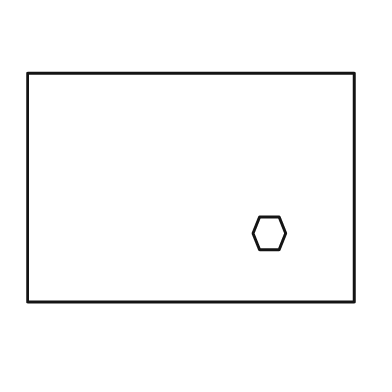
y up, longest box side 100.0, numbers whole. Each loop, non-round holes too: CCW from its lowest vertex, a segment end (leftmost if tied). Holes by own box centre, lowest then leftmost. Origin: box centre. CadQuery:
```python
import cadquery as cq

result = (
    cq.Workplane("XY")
    .moveTo(-50.0, -35.0)
    .lineTo(50.0, -35.0)
    .lineTo(50.0, 35.0)
    .lineTo(-50.0, 35.0)
    .close()
    .moveTo(21.0, -19.0)
    .lineTo(27.0, -19.0)
    .lineTo(29.0, -14.0)
    .lineTo(27.0, -9.0)
    .lineTo(21.0, -9.0)
    .lineTo(19.0, -14.0)
    .close()
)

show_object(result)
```